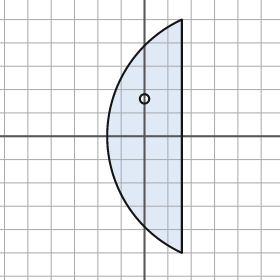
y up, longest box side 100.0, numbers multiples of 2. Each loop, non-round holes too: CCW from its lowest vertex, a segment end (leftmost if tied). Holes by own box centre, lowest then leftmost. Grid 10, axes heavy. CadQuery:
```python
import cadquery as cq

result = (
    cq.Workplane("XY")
    .moveTo(16.0, -50.0)
    .lineTo(16.0, 50.0)
    .threePointArc((-16.0, 0.0), (16.0, -50.0))
    .close()
    .moveTo(0.0, 16.0)
    .circle(2.0)
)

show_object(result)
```